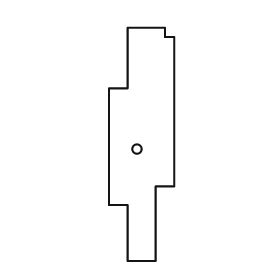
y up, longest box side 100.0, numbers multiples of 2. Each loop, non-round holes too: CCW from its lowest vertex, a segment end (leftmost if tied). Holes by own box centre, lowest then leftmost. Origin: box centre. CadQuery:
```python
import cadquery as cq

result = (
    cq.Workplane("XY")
    .moveTo(-6.0, -50.0)
    .lineTo(6.0, -50.0)
    .lineTo(6.0, -18.0)
    .lineTo(14.0, -18.0)
    .lineTo(14.0, 46.0)
    .lineTo(10.0, 46.0)
    .lineTo(10.0, 50.0)
    .lineTo(-6.0, 50.0)
    .lineTo(-6.0, 24.0)
    .lineTo(-14.0, 24.0)
    .lineTo(-14.0, -26.0)
    .lineTo(-6.0, -26.0)
    .close()
    .moveTo(-2.0, -2.0)
    .circle(2.0)
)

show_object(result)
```